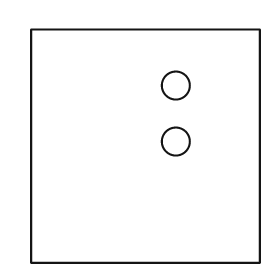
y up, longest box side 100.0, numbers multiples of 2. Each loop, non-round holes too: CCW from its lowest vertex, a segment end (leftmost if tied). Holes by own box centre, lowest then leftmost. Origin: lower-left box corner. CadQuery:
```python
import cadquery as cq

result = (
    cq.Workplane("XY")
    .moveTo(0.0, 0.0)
    .lineTo(98.0, 0.0)
    .lineTo(98.0, 100.0)
    .lineTo(0.0, 100.0)
    .close()
    .moveTo(62.0, 52.0)
    .circle(6.0)
    .moveTo(62.0, 76.0)
    .circle(6.0)
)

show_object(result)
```